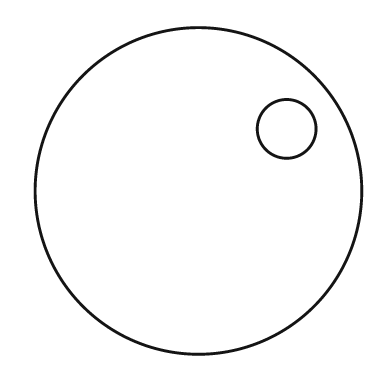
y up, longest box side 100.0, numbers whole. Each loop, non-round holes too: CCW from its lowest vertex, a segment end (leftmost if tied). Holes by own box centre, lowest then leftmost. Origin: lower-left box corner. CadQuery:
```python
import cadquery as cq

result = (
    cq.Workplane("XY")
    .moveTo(50.0, 50.0)
    .circle(50.0)
    .moveTo(77.0, 69.0)
    .circle(9.0)
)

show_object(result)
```